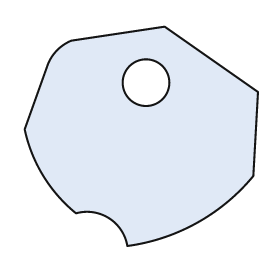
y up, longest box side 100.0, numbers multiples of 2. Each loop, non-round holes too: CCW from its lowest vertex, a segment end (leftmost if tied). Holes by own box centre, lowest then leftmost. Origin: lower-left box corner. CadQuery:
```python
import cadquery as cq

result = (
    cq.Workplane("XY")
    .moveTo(44.0, 0.0)
    .threePointArc((74.0, 10.0), (98.0, 30.0))
    .lineTo(100.0, 66.0)
    .lineTo(60.0, 94.0)
    .lineTo(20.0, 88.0)
    .threePointArc((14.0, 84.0), (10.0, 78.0))
    .lineTo(0.0, 50.0)
    .threePointArc((8.0, 30.0), (22.0, 14.0))
    .threePointArc((36.0, 12.0), (44.0, 0.0))
    .close()
    .moveTo(52.0, 70.0)
    .circle(10.0)
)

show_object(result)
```